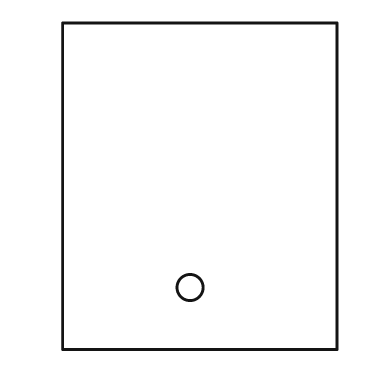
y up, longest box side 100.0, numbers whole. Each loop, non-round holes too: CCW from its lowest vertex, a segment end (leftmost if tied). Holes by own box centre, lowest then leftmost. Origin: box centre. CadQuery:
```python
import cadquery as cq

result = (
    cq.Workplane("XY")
    .moveTo(-42.0, -50.0)
    .lineTo(42.0, -50.0)
    .lineTo(42.0, 50.0)
    .lineTo(-42.0, 50.0)
    .close()
    .moveTo(-3.0, -31.0)
    .circle(4.0)
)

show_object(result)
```